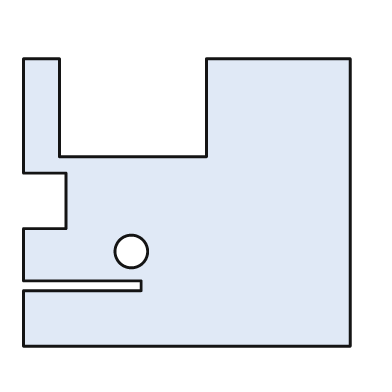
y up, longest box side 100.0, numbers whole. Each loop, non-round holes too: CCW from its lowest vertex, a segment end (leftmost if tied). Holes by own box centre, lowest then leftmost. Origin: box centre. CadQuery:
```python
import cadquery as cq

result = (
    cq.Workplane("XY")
    .moveTo(-50.0, -44.0)
    .lineTo(50.0, -44.0)
    .lineTo(50.0, 44.0)
    .lineTo(6.0, 44.0)
    .lineTo(6.0, 14.0)
    .lineTo(-39.0, 14.0)
    .lineTo(-39.0, 44.0)
    .lineTo(-50.0, 44.0)
    .lineTo(-50.0, 9.0)
    .lineTo(-37.0, 9.0)
    .lineTo(-37.0, -8.0)
    .lineTo(-50.0, -8.0)
    .lineTo(-50.0, -24.0)
    .lineTo(-14.0, -24.0)
    .lineTo(-14.0, -27.0)
    .lineTo(-50.0, -27.0)
    .close()
    .moveTo(-17.0, -15.0)
    .circle(5.0)
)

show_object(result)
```